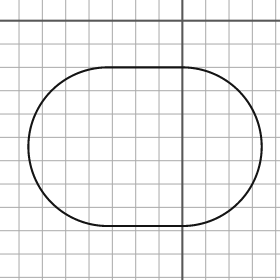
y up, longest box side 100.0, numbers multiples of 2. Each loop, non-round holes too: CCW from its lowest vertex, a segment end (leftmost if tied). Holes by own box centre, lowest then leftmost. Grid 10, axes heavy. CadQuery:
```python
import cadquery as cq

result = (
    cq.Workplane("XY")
    .moveTo(-32.0, -88.0)
    .lineTo(0.0, -88.0)
    .threePointArc((34.0, -54.0), (0.0, -20.0))
    .lineTo(-32.0, -20.0)
    .threePointArc((-66.0, -54.0), (-32.0, -88.0))
    .close()
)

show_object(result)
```